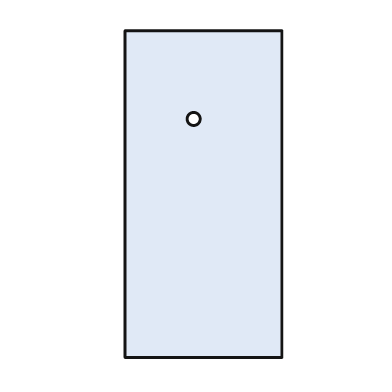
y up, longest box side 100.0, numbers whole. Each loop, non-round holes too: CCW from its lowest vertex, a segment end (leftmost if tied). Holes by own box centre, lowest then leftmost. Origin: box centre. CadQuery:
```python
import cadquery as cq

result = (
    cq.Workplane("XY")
    .moveTo(-24.0, -50.0)
    .lineTo(24.0, -50.0)
    .lineTo(24.0, 50.0)
    .lineTo(-24.0, 50.0)
    .close()
    .moveTo(-3.0, 23.0)
    .circle(2.0)
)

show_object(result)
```